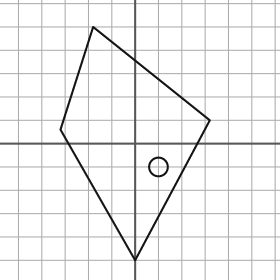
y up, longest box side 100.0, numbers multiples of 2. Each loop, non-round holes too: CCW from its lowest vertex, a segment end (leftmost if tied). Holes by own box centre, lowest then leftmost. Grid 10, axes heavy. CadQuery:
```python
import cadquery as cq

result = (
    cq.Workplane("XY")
    .moveTo(0.0, -50.0)
    .lineTo(32.0, 10.0)
    .lineTo(-18.0, 50.0)
    .lineTo(-32.0, 6.0)
    .close()
    .moveTo(10.0, -10.0)
    .circle(4.0)
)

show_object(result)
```